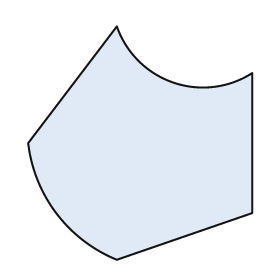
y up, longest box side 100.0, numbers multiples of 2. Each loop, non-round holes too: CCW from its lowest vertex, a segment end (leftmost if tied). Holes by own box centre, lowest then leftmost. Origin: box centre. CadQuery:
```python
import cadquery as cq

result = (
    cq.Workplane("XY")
    .moveTo(-10.0, -50.0)
    .lineTo(48.0, -30.0)
    .lineTo(48.0, 30.0)
    .threePointArc((14.0, 26.0), (-10.0, 50.0))
    .lineTo(-48.0, 0.0)
    .threePointArc((-36.0, -30.0), (-10.0, -50.0))
    .close()
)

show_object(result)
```